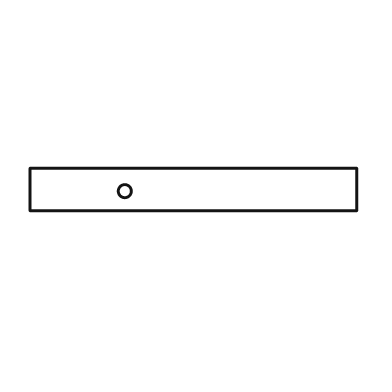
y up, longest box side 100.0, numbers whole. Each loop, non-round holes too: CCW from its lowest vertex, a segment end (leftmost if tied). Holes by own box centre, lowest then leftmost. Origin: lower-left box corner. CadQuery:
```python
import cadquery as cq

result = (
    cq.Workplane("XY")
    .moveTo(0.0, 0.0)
    .lineTo(100.0, 0.0)
    .lineTo(100.0, 13.0)
    .lineTo(0.0, 13.0)
    .close()
    .moveTo(29.0, 6.0)
    .circle(2.0)
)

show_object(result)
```